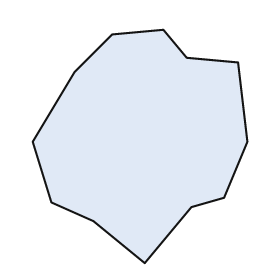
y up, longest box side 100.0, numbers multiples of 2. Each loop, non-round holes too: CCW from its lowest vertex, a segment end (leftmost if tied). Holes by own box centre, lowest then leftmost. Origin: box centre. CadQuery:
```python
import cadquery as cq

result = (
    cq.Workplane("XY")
    .moveTo(2.0, -50.0)
    .lineTo(22.0, -26.0)
    .lineTo(36.0, -22.0)
    .lineTo(46.0, 2.0)
    .lineTo(42.0, 36.0)
    .lineTo(20.0, 38.0)
    .lineTo(10.0, 50.0)
    .lineTo(-12.0, 48.0)
    .lineTo(-28.0, 32.0)
    .lineTo(-46.0, 2.0)
    .lineTo(-38.0, -24.0)
    .lineTo(-20.0, -32.0)
    .close()
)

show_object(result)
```